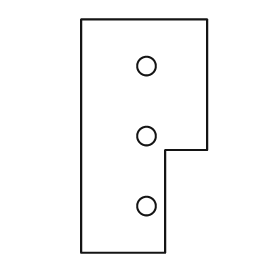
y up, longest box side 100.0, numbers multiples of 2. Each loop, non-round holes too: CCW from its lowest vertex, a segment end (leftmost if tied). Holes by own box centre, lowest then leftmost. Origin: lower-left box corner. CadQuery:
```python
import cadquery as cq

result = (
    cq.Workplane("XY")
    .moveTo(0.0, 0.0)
    .lineTo(36.0, 0.0)
    .lineTo(36.0, 44.0)
    .lineTo(54.0, 44.0)
    .lineTo(54.0, 100.0)
    .lineTo(0.0, 100.0)
    .close()
    .moveTo(28.0, 20.0)
    .circle(4.0)
    .moveTo(28.0, 50.0)
    .circle(4.0)
    .moveTo(28.0, 80.0)
    .circle(4.0)
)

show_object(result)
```